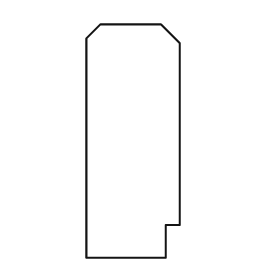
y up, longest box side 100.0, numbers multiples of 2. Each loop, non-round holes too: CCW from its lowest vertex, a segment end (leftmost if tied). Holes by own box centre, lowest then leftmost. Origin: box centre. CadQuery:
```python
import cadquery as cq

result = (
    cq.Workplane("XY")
    .moveTo(-20.0, -50.0)
    .lineTo(14.0, -50.0)
    .lineTo(14.0, -36.0)
    .lineTo(20.0, -36.0)
    .lineTo(20.0, 42.0)
    .lineTo(12.0, 50.0)
    .lineTo(-14.0, 50.0)
    .lineTo(-20.0, 44.0)
    .close()
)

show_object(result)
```